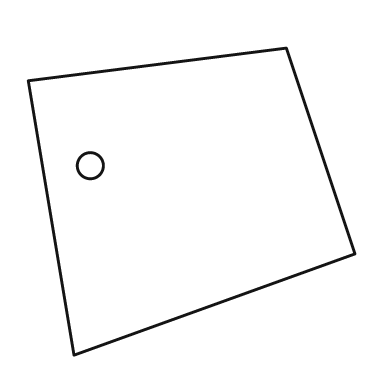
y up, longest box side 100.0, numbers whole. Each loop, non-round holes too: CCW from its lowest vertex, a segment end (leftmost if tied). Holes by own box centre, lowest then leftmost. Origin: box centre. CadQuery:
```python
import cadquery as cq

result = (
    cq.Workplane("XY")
    .moveTo(-36.0, -47.0)
    .lineTo(50.0, -16.0)
    .lineTo(29.0, 47.0)
    .lineTo(-50.0, 37.0)
    .close()
    .moveTo(-31.0, 11.0)
    .circle(4.0)
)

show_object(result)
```